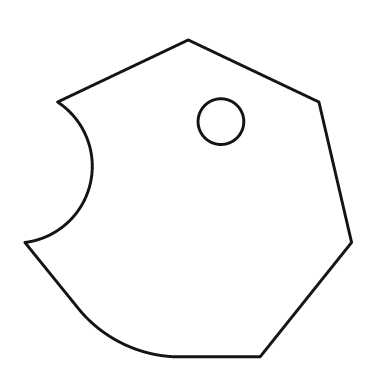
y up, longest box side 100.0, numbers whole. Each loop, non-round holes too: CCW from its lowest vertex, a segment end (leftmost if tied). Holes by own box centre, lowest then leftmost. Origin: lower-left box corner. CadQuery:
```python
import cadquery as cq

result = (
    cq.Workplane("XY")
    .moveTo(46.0, 0.0)
    .lineTo(72.0, 0.0)
    .lineTo(100.0, 35.0)
    .lineTo(90.0, 78.0)
    .lineTo(50.0, 97.0)
    .lineTo(10.0, 78.0)
    .threePointArc((20.0, 53.0), (0.0, 35.0))
    .lineTo(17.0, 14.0)
    .threePointArc((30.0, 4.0), (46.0, 0.0))
    .close()
    .moveTo(60.0, 72.0)
    .circle(7.0)
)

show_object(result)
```